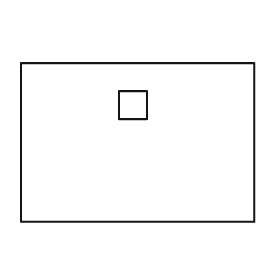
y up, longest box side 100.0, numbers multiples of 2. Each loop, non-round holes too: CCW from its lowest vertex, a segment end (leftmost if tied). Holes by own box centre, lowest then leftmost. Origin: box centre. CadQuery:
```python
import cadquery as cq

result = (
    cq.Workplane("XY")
    .moveTo(-50.0, -34.0)
    .lineTo(50.0, -34.0)
    .lineTo(50.0, 34.0)
    .lineTo(-50.0, 34.0)
    .close()
    .moveTo(-8.0, 10.0)
    .lineTo(4.0, 10.0)
    .lineTo(4.0, 22.0)
    .lineTo(-8.0, 22.0)
    .close()
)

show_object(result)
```